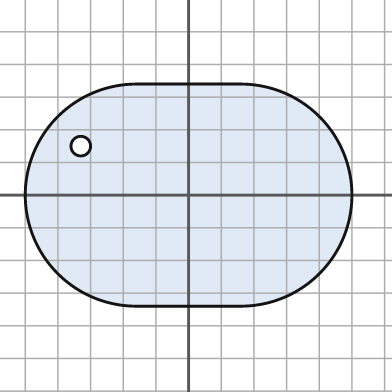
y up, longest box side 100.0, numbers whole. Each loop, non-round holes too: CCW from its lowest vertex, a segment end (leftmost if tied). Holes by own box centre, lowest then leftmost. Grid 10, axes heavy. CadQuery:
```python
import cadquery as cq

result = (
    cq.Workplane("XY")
    .moveTo(-16.0, -34.0)
    .lineTo(16.0, -34.0)
    .threePointArc((50.0, 0.0), (16.0, 34.0))
    .lineTo(-16.0, 34.0)
    .threePointArc((-50.0, 0.0), (-16.0, -34.0))
    .close()
    .moveTo(-33.0, 15.0)
    .circle(3.0)
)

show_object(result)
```